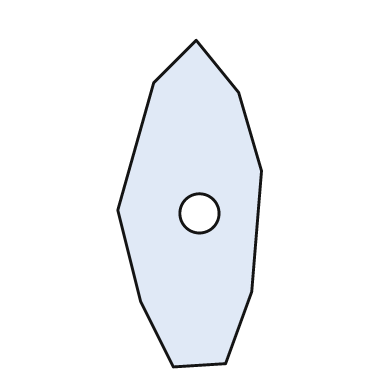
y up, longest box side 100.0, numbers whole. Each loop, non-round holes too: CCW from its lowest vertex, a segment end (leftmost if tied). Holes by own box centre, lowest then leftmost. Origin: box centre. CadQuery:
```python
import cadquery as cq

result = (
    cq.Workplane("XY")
    .moveTo(-5.0, -50.0)
    .lineTo(11.0, -49.0)
    .lineTo(19.0, -27.0)
    .lineTo(22.0, 10.0)
    .lineTo(15.0, 34.0)
    .lineTo(2.0, 50.0)
    .lineTo(-11.0, 37.0)
    .lineTo(-22.0, -2.0)
    .lineTo(-15.0, -30.0)
    .close()
    .moveTo(3.0, -3.0)
    .circle(6.0)
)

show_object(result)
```